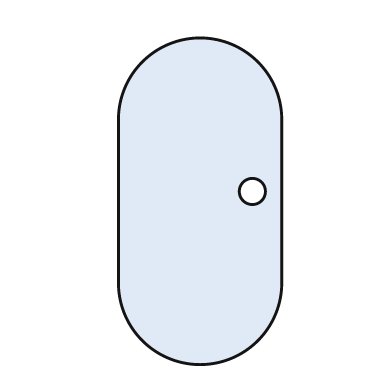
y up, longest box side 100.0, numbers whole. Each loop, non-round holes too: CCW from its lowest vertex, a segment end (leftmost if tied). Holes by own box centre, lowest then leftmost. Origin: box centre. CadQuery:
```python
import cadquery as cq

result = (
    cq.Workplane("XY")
    .moveTo(-25.0, -25.0)
    .threePointArc((0.0, -50.0), (25.0, -25.0))
    .lineTo(25.0, 25.0)
    .threePointArc((0.0, 50.0), (-25.0, 25.0))
    .close()
    .moveTo(16.0, 3.0)
    .circle(4.0)
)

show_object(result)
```